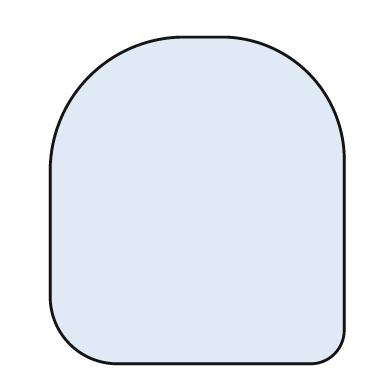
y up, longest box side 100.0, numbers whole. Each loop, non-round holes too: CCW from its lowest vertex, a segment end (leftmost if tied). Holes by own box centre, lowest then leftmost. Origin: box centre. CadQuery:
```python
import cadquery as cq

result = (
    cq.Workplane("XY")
    .moveTo(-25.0, -50.0)
    .lineTo(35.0, -50.0)
    .threePointArc((42.0, -47.0), (45.0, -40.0))
    .lineTo(45.0, 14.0)
    .threePointArc((34.0, 39.0), (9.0, 50.0))
    .lineTo(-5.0, 50.0)
    .threePointArc((-33.0, 38.0), (-45.0, 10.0))
    .lineTo(-45.0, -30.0)
    .threePointArc((-39.0, -44.0), (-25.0, -50.0))
    .close()
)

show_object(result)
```